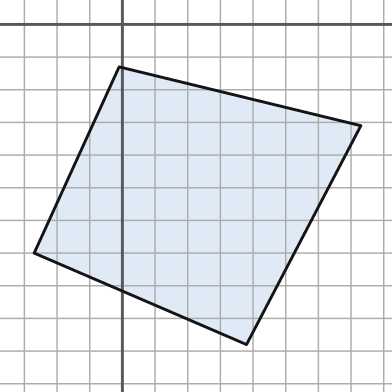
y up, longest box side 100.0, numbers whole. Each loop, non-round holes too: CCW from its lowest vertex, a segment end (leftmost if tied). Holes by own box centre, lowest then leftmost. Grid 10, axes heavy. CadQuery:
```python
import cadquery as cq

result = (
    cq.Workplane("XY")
    .moveTo(38.0, -98.0)
    .lineTo(73.0, -31.0)
    .lineTo(-1.0, -13.0)
    .lineTo(-27.0, -70.0)
    .close()
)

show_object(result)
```